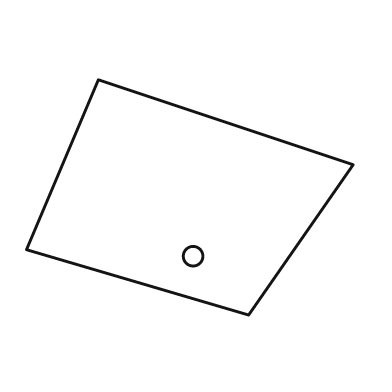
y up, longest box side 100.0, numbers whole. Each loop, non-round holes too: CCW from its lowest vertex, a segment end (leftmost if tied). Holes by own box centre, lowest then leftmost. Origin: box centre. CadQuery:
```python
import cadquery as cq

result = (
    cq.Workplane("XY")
    .moveTo(18.0, -36.0)
    .lineTo(50.0, 10.0)
    .lineTo(-28.0, 36.0)
    .lineTo(-50.0, -16.0)
    .close()
    .moveTo(1.0, -18.0)
    .circle(3.0)
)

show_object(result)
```